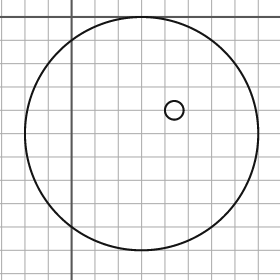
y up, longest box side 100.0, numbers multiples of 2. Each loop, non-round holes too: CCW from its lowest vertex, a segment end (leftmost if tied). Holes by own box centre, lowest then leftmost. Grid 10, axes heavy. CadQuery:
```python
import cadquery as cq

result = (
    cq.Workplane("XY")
    .moveTo(30.0, -50.0)
    .circle(50.0)
    .moveTo(44.0, -40.0)
    .circle(4.0)
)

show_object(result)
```